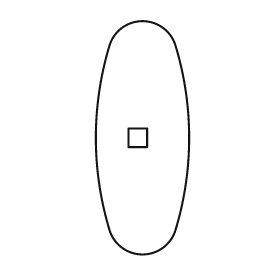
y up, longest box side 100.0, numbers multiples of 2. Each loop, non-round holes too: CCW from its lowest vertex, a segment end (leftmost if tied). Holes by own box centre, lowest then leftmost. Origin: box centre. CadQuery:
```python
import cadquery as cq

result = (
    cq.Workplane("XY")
    .moveTo(-14.0, -40.0)
    .threePointArc((0.0, -50.0), (14.0, -40.0))
    .threePointArc((20.0, 0.0), (14.0, 40.0))
    .threePointArc((0.0, 50.0), (-14.0, 40.0))
    .threePointArc((-20.0, 0.0), (-14.0, -40.0))
    .close()
    .moveTo(-6.0, -4.0)
    .lineTo(2.0, -4.0)
    .lineTo(2.0, 4.0)
    .lineTo(-6.0, 4.0)
    .close()
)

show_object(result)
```